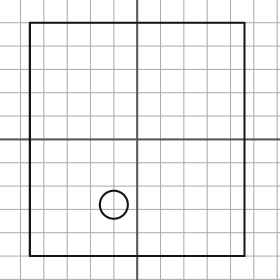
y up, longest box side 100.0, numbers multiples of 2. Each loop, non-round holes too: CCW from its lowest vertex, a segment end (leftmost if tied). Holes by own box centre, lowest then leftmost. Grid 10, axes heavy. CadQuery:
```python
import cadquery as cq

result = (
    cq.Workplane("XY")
    .moveTo(-46.0, -50.0)
    .lineTo(46.0, -50.0)
    .lineTo(46.0, 50.0)
    .lineTo(-46.0, 50.0)
    .close()
    .moveTo(-10.0, -28.0)
    .circle(6.0)
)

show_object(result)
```